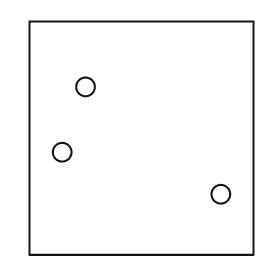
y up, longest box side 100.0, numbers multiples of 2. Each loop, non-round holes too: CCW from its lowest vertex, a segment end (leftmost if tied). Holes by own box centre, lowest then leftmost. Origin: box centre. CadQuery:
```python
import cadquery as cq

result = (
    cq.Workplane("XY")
    .moveTo(-48.0, -50.0)
    .lineTo(48.0, -50.0)
    .lineTo(48.0, 50.0)
    .lineTo(-48.0, 50.0)
    .close()
    .moveTo(34.0, -24.0)
    .circle(4.0)
    .moveTo(-34.0, -6.0)
    .circle(4.0)
    .moveTo(-24.0, 22.0)
    .circle(4.0)
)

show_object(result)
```